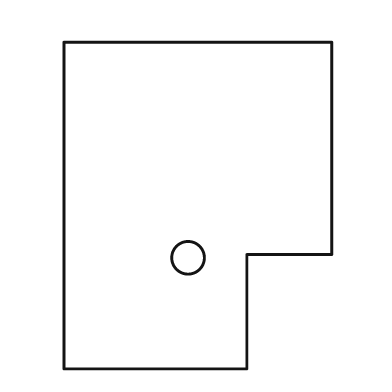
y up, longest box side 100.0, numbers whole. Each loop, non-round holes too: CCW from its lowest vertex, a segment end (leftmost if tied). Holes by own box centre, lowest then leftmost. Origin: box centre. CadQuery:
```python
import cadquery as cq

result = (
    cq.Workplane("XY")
    .moveTo(-41.0, -50.0)
    .lineTo(15.0, -50.0)
    .lineTo(15.0, -15.0)
    .lineTo(41.0, -15.0)
    .lineTo(41.0, 50.0)
    .lineTo(-41.0, 50.0)
    .close()
    .moveTo(-3.0, -16.0)
    .circle(5.0)
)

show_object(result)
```